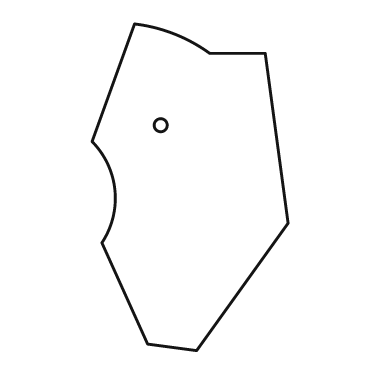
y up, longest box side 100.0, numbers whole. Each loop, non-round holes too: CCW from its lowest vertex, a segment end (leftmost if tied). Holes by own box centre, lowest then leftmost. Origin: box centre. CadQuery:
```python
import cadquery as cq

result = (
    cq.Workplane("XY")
    .moveTo(2.0, -50.0)
    .lineTo(30.0, -11.0)
    .lineTo(23.0, 41.0)
    .lineTo(6.0, 41.0)
    .threePointArc((-5.0, 47.0), (-17.0, 50.0))
    .lineTo(-30.0, 14.0)
    .threePointArc((-23.0, -1.0), (-27.0, -17.0))
    .lineTo(-13.0, -48.0)
    .close()
    .moveTo(-9.0, 19.0)
    .circle(2.0)
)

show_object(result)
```